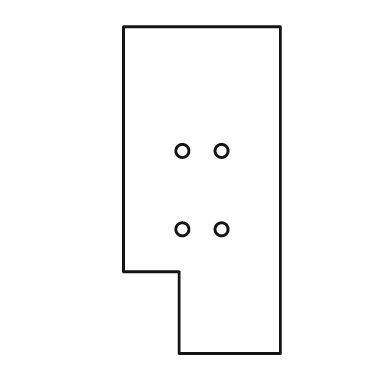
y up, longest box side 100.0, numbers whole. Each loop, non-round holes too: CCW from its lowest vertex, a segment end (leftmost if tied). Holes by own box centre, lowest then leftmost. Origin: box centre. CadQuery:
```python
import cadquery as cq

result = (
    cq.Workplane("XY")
    .moveTo(-7.0, -50.0)
    .lineTo(24.0, -50.0)
    .lineTo(24.0, 50.0)
    .lineTo(-24.0, 50.0)
    .lineTo(-24.0, -25.0)
    .lineTo(-7.0, -25.0)
    .close()
    .moveTo(-6.0, -12.0)
    .circle(2.0)
    .moveTo(6.0, -12.0)
    .circle(2.0)
    .moveTo(-6.0, 12.0)
    .circle(2.0)
    .moveTo(6.0, 12.0)
    .circle(2.0)
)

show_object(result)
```